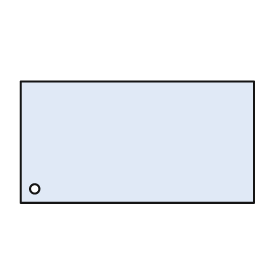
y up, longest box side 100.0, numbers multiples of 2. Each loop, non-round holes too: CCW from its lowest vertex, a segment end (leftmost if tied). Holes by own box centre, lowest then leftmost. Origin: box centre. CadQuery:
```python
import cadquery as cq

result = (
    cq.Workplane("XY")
    .moveTo(-50.0, -26.0)
    .lineTo(50.0, -26.0)
    .lineTo(50.0, 26.0)
    .lineTo(-50.0, 26.0)
    .close()
    .moveTo(-44.0, -20.0)
    .circle(2.0)
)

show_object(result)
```